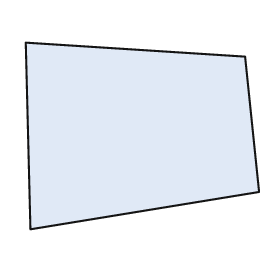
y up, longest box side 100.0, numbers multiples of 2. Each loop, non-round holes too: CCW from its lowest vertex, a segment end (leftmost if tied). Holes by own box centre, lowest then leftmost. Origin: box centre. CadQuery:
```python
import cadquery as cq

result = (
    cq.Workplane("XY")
    .moveTo(-48.0, -40.0)
    .lineTo(50.0, -24.0)
    .lineTo(44.0, 34.0)
    .lineTo(-50.0, 40.0)
    .close()
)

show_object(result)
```